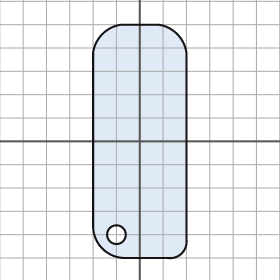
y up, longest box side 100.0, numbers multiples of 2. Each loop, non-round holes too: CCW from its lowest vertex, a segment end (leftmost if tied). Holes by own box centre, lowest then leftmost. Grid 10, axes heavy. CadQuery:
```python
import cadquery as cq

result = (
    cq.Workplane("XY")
    .moveTo(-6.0, -50.0)
    .lineTo(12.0, -50.0)
    .threePointArc((18.0, -48.0), (20.0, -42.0))
    .lineTo(20.0, 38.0)
    .threePointArc((16.0, 46.0), (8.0, 50.0))
    .lineTo(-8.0, 50.0)
    .threePointArc((-16.0, 46.0), (-20.0, 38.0))
    .lineTo(-20.0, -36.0)
    .threePointArc((-16.0, -46.0), (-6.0, -50.0))
    .close()
    .moveTo(-10.0, -40.0)
    .circle(4.0)
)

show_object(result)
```